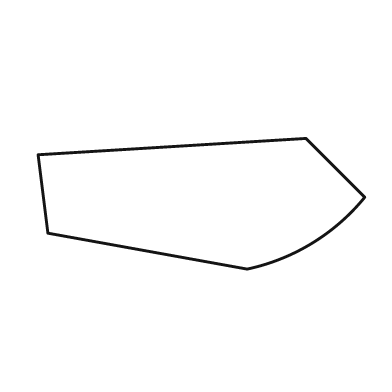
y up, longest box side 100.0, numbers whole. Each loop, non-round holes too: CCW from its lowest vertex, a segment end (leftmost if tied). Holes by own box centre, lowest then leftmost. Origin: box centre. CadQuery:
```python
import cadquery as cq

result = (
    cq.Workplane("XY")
    .moveTo(14.0, -20.0)
    .threePointArc((34.0, -12.0), (50.0, 2.0))
    .lineTo(32.0, 20.0)
    .lineTo(-50.0, 15.0)
    .lineTo(-47.0, -9.0)
    .close()
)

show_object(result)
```